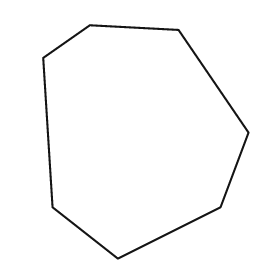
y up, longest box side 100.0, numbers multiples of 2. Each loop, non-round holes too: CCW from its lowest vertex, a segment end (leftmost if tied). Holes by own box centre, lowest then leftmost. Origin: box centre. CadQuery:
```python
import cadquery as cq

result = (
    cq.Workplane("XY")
    .moveTo(-12.0, -50.0)
    .lineTo(32.0, -28.0)
    .lineTo(44.0, 4.0)
    .lineTo(14.0, 48.0)
    .lineTo(-24.0, 50.0)
    .lineTo(-44.0, 36.0)
    .lineTo(-40.0, -28.0)
    .close()
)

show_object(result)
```